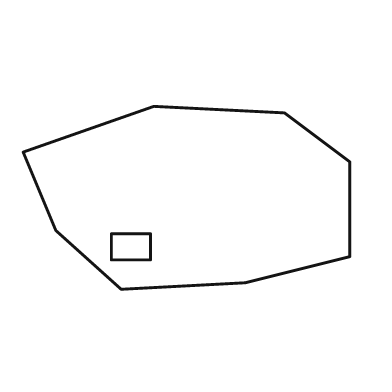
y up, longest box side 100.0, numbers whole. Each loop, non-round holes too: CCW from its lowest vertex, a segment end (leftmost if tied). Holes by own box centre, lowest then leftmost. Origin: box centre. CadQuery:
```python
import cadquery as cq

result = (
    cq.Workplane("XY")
    .moveTo(-20.0, -28.0)
    .lineTo(18.0, -26.0)
    .lineTo(50.0, -18.0)
    .lineTo(50.0, 11.0)
    .lineTo(30.0, 26.0)
    .lineTo(-10.0, 28.0)
    .lineTo(-50.0, 14.0)
    .lineTo(-40.0, -10.0)
    .close()
    .moveTo(-23.0, -19.0)
    .lineTo(-11.0, -19.0)
    .lineTo(-11.0, -11.0)
    .lineTo(-23.0, -11.0)
    .close()
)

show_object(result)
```